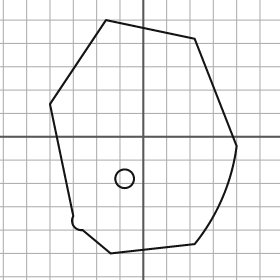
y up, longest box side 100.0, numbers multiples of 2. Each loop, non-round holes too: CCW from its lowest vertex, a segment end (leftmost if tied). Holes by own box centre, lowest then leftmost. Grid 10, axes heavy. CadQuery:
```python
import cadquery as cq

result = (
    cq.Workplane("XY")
    .moveTo(-14.0, -50.0)
    .lineTo(22.0, -46.0)
    .threePointArc((34.0, -26.0), (40.0, -4.0))
    .lineTo(22.0, 42.0)
    .lineTo(-16.0, 50.0)
    .lineTo(-40.0, 14.0)
    .lineTo(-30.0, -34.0)
    .threePointArc((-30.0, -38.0), (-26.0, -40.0))
    .close()
    .moveTo(-8.0, -18.0)
    .circle(4.0)
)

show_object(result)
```